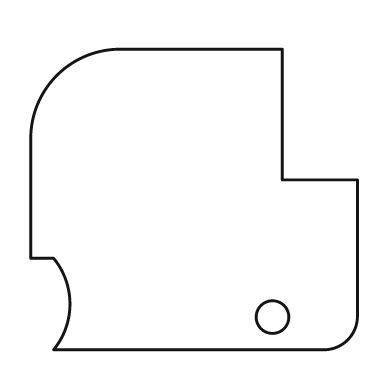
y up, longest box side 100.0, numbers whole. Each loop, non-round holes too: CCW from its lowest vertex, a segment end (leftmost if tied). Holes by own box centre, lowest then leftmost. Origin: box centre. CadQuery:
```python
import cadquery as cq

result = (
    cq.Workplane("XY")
    .moveTo(-43.0, -46.0)
    .lineTo(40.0, -46.0)
    .threePointArc((47.0, -43.0), (50.0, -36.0))
    .lineTo(50.0, 6.0)
    .lineTo(27.0, 6.0)
    .lineTo(27.0, 46.0)
    .lineTo(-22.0, 46.0)
    .threePointArc((-42.0, 38.0), (-50.0, 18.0))
    .lineTo(-50.0, -18.0)
    .lineTo(-43.0, -18.0)
    .threePointArc((-38.0, -32.0), (-43.0, -46.0))
    .close()
    .moveTo(24.0, -36.0)
    .circle(5.0)
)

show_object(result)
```